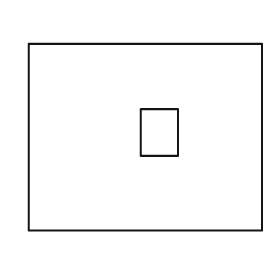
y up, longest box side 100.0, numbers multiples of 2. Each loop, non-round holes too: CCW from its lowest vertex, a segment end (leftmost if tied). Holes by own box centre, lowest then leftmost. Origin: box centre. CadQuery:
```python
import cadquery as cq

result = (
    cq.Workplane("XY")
    .moveTo(-50.0, -40.0)
    .lineTo(50.0, -40.0)
    .lineTo(50.0, 40.0)
    .lineTo(-50.0, 40.0)
    .close()
    .moveTo(-2.0, -8.0)
    .lineTo(14.0, -8.0)
    .lineTo(14.0, 12.0)
    .lineTo(-2.0, 12.0)
    .close()
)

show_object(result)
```